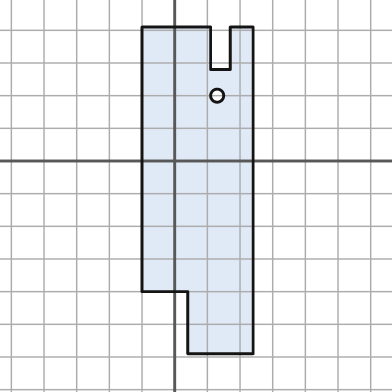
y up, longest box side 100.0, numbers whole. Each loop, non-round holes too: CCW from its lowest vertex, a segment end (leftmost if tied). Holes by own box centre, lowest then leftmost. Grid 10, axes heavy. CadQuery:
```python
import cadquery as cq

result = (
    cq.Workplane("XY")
    .moveTo(4.0, -59.0)
    .lineTo(24.0, -59.0)
    .lineTo(24.0, 41.0)
    .lineTo(17.0, 41.0)
    .lineTo(17.0, 28.0)
    .lineTo(11.0, 28.0)
    .lineTo(11.0, 41.0)
    .lineTo(-10.0, 41.0)
    .lineTo(-10.0, -40.0)
    .lineTo(4.0, -40.0)
    .close()
    .moveTo(13.0, 20.0)
    .circle(2.0)
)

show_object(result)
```